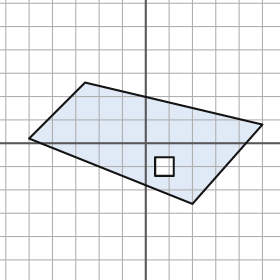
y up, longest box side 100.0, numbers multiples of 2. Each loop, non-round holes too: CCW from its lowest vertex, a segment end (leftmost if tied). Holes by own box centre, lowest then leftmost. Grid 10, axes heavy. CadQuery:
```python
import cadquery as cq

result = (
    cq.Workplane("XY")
    .moveTo(20.0, -26.0)
    .lineTo(50.0, 8.0)
    .lineTo(-26.0, 26.0)
    .lineTo(-50.0, 2.0)
    .close()
    .moveTo(4.0, -14.0)
    .lineTo(12.0, -14.0)
    .lineTo(12.0, -6.0)
    .lineTo(4.0, -6.0)
    .close()
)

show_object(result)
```